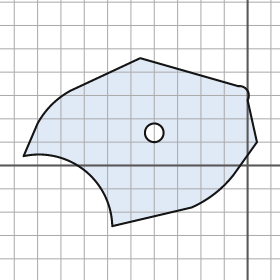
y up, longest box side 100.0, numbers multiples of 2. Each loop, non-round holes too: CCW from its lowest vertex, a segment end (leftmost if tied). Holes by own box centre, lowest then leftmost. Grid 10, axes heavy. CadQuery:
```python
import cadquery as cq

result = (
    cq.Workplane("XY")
    .moveTo(-58.0, -26.0)
    .lineTo(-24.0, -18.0)
    .threePointArc((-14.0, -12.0), (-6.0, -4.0))
    .lineTo(4.0, 10.0)
    .lineTo(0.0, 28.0)
    .threePointArc((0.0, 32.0), (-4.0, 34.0))
    .lineTo(-46.0, 46.0)
    .lineTo(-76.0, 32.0)
    .threePointArc((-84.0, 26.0), (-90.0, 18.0))
    .lineTo(-96.0, 4.0)
    .threePointArc((-70.0, -2.0), (-58.0, -26.0))
    .close()
    .moveTo(-40.0, 14.0)
    .circle(4.0)
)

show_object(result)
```